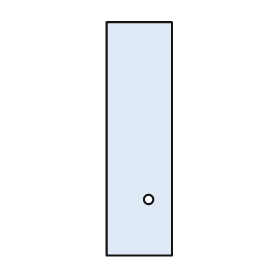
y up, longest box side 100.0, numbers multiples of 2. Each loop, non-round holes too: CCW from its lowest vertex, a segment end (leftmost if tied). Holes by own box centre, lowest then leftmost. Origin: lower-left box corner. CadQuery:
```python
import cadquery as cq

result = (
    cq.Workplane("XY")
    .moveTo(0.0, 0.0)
    .lineTo(28.0, 0.0)
    .lineTo(28.0, 100.0)
    .lineTo(0.0, 100.0)
    .close()
    .moveTo(18.0, 24.0)
    .circle(2.0)
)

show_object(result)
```